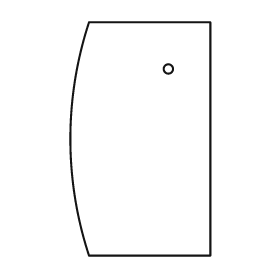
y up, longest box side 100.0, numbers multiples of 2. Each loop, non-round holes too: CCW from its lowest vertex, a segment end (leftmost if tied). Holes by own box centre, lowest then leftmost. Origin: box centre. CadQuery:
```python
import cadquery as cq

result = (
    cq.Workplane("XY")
    .moveTo(-22.0, -50.0)
    .lineTo(30.0, -50.0)
    .lineTo(30.0, 50.0)
    .lineTo(-22.0, 50.0)
    .threePointArc((-30.0, 0.0), (-22.0, -50.0))
    .close()
    .moveTo(12.0, 30.0)
    .circle(2.0)
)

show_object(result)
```